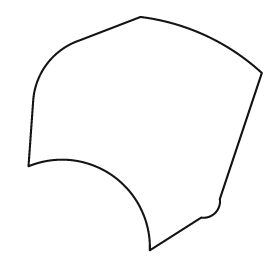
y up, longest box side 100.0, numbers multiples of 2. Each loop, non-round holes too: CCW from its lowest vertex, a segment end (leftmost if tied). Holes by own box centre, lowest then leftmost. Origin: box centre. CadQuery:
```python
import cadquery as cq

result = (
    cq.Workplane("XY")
    .moveTo(2.0, -50.0)
    .lineTo(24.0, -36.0)
    .threePointArc((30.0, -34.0), (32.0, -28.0))
    .lineTo(50.0, 26.0)
    .threePointArc((26.0, 42.0), (-2.0, 50.0))
    .lineTo(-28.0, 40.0)
    .threePointArc((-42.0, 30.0), (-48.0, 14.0))
    .lineTo(-50.0, -14.0)
    .threePointArc((-14.0, -18.0), (2.0, -50.0))
    .close()
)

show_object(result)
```